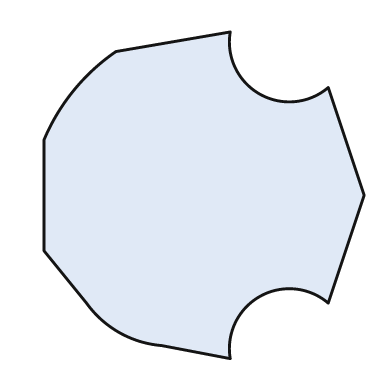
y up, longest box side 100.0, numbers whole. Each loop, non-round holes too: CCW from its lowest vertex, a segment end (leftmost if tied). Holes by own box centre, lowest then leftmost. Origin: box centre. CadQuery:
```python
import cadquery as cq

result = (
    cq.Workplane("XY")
    .moveTo(8.0, -50.0)
    .threePointArc((17.0, -31.0), (38.0, -33.0))
    .lineTo(49.0, 0.0)
    .lineTo(38.0, 33.0)
    .threePointArc((17.0, 31.0), (8.0, 50.0))
    .lineTo(-27.0, 44.0)
    .threePointArc((-40.0, 32.0), (-49.0, 17.0))
    .lineTo(-49.0, -17.0)
    .lineTo(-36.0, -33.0)
    .threePointArc((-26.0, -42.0), (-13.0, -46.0))
    .close()
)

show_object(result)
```